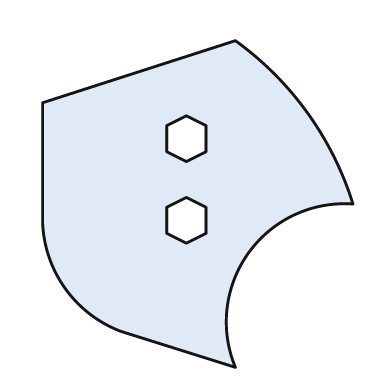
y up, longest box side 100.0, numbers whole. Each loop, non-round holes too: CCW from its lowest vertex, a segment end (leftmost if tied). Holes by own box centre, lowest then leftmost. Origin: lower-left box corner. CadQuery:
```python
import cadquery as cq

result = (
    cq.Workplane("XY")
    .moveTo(59.0, 0.0)
    .threePointArc((63.0, 35.0), (95.0, 50.0))
    .threePointArc((81.0, 78.0), (59.0, 100.0))
    .lineTo(0.0, 81.0)
    .lineTo(0.0, 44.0)
    .threePointArc((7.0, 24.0), (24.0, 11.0))
    .close()
    .moveTo(44.0, 38.0)
    .lineTo(50.0, 41.0)
    .lineTo(50.0, 49.0)
    .lineTo(44.0, 52.0)
    .lineTo(38.0, 49.0)
    .lineTo(38.0, 41.0)
    .close()
    .moveTo(44.0, 63.0)
    .lineTo(50.0, 66.0)
    .lineTo(50.0, 74.0)
    .lineTo(44.0, 77.0)
    .lineTo(38.0, 74.0)
    .lineTo(38.0, 66.0)
    .close()
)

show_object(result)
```